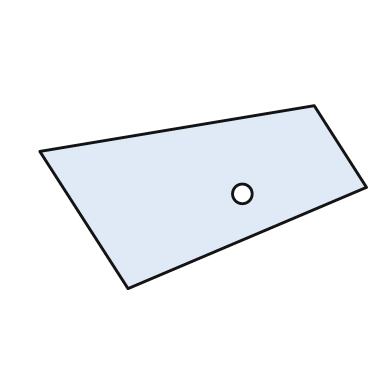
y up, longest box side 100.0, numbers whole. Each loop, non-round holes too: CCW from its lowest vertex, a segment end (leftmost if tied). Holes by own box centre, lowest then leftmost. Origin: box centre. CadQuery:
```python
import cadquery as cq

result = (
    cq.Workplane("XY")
    .moveTo(-23.0, -28.0)
    .lineTo(50.0, 3.0)
    .lineTo(34.0, 28.0)
    .lineTo(-50.0, 14.0)
    .close()
    .moveTo(12.0, 1.0)
    .circle(3.0)
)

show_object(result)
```